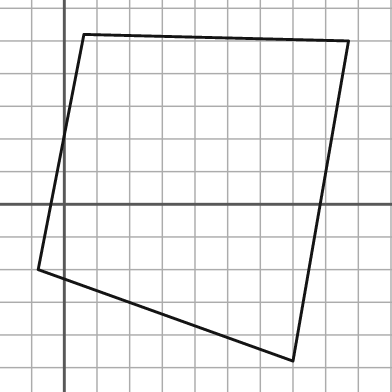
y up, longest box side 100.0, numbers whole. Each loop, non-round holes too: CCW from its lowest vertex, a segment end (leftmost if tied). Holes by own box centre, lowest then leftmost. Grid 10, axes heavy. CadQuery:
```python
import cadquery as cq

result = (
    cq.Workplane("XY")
    .moveTo(70.0, -48.0)
    .lineTo(87.0, 50.0)
    .lineTo(6.0, 52.0)
    .lineTo(-8.0, -20.0)
    .close()
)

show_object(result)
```